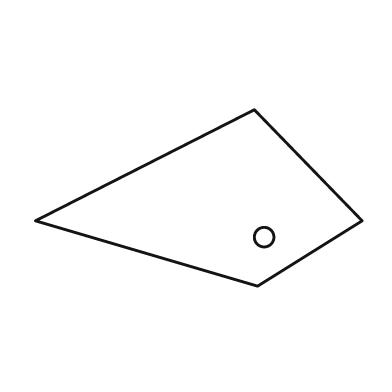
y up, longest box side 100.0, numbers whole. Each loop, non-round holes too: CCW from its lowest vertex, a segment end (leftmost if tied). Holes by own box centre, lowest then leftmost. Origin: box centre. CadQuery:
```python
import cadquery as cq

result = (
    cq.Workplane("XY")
    .moveTo(18.0, -27.0)
    .lineTo(50.0, -7.0)
    .lineTo(17.0, 27.0)
    .lineTo(-50.0, -7.0)
    .close()
    .moveTo(20.0, -12.0)
    .circle(3.0)
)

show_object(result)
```